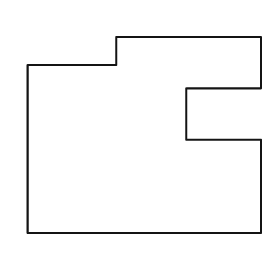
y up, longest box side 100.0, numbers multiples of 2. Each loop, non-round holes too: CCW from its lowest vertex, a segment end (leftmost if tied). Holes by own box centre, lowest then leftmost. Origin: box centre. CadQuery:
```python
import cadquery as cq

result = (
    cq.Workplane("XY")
    .moveTo(-50.0, -42.0)
    .lineTo(50.0, -42.0)
    .lineTo(50.0, -2.0)
    .lineTo(18.0, -2.0)
    .lineTo(18.0, 20.0)
    .lineTo(50.0, 20.0)
    .lineTo(50.0, 42.0)
    .lineTo(-12.0, 42.0)
    .lineTo(-12.0, 30.0)
    .lineTo(-50.0, 30.0)
    .close()
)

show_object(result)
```